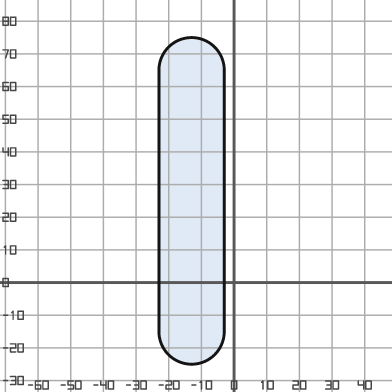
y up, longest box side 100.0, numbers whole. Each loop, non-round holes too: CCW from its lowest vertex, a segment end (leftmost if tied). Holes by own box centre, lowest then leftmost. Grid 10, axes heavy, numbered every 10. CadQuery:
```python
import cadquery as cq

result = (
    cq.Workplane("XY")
    .moveTo(-23.0, -15.0)
    .threePointArc((-13.0, -25.0), (-3.0, -15.0))
    .lineTo(-3.0, 65.0)
    .threePointArc((-13.0, 75.0), (-23.0, 65.0))
    .close()
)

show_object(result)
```